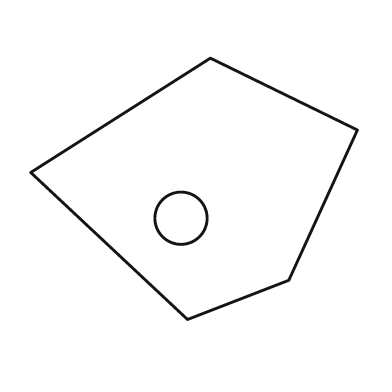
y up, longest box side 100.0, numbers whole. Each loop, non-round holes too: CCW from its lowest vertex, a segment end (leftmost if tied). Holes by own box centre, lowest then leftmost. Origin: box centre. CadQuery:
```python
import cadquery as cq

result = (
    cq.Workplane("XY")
    .moveTo(-2.0, -40.0)
    .lineTo(29.0, -28.0)
    .lineTo(50.0, 18.0)
    .lineTo(5.0, 40.0)
    .lineTo(-50.0, 5.0)
    .close()
    .moveTo(-4.0, -9.0)
    .circle(8.0)
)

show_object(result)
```